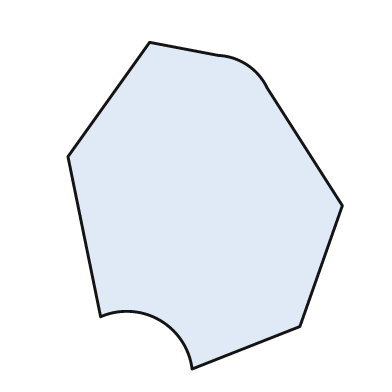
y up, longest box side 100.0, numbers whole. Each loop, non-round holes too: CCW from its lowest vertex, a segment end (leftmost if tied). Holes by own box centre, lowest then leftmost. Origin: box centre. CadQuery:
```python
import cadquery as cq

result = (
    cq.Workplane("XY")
    .moveTo(-4.0, -50.0)
    .lineTo(29.0, -37.0)
    .lineTo(42.0, 0.0)
    .lineTo(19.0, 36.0)
    .threePointArc((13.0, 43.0), (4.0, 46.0))
    .lineTo(-17.0, 50.0)
    .lineTo(-42.0, 15.0)
    .lineTo(-32.0, -34.0)
    .threePointArc((-14.0, -35.0), (-4.0, -50.0))
    .close()
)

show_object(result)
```